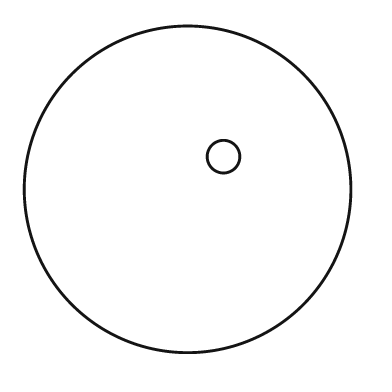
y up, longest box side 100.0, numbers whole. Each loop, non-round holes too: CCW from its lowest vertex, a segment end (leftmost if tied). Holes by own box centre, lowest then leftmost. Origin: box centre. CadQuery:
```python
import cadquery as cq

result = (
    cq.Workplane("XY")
    .moveTo(0.0, 0.0)
    .circle(50.0)
    .moveTo(11.0, 10.0)
    .circle(5.0)
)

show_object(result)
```